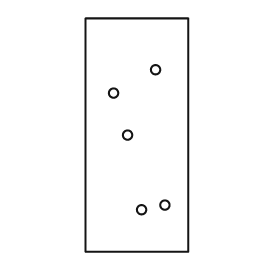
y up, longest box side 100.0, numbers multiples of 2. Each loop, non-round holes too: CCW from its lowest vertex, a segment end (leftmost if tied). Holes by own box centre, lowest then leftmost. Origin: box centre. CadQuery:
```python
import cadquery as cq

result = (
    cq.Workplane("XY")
    .moveTo(-22.0, -50.0)
    .lineTo(22.0, -50.0)
    .lineTo(22.0, 50.0)
    .lineTo(-22.0, 50.0)
    .close()
    .moveTo(2.0, -32.0)
    .circle(2.0)
    .moveTo(12.0, -30.0)
    .circle(2.0)
    .moveTo(-4.0, 0.0)
    .circle(2.0)
    .moveTo(-10.0, 18.0)
    .circle(2.0)
    .moveTo(8.0, 28.0)
    .circle(2.0)
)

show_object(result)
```